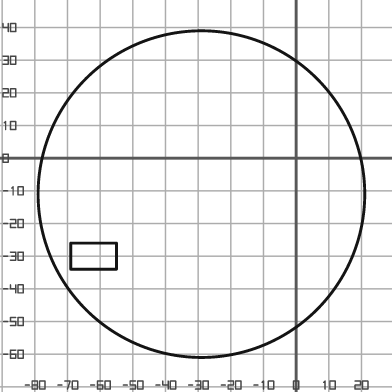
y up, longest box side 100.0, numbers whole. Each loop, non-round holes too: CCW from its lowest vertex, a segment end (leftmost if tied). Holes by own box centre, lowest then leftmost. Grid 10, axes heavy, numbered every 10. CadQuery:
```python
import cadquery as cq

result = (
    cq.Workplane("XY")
    .moveTo(-29.0, -11.0)
    .circle(50.0)
    .moveTo(-69.0, -34.0)
    .lineTo(-55.0, -34.0)
    .lineTo(-55.0, -26.0)
    .lineTo(-69.0, -26.0)
    .close()
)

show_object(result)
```